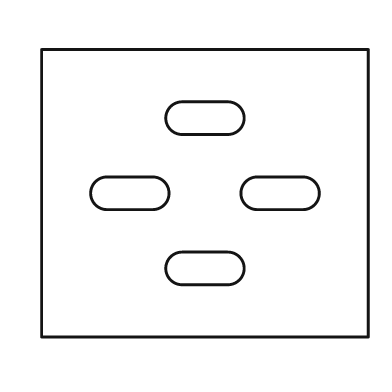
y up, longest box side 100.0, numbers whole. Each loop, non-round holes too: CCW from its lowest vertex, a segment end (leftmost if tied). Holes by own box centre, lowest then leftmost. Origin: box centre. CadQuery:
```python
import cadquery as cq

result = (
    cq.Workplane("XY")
    .moveTo(-50.0, -44.0)
    .lineTo(50.0, -44.0)
    .lineTo(50.0, 44.0)
    .lineTo(-50.0, 44.0)
    .close()
    .moveTo(-7.0, -28.0)
    .lineTo(7.0, -28.0)
    .threePointArc((12.0, -23.0), (7.0, -18.0))
    .lineTo(-7.0, -18.0)
    .threePointArc((-12.0, -23.0), (-7.0, -28.0))
    .close()
    .moveTo(-30.0, -5.0)
    .lineTo(-16.0, -5.0)
    .threePointArc((-11.0, 0.0), (-16.0, 5.0))
    .lineTo(-30.0, 5.0)
    .threePointArc((-35.0, 0.0), (-30.0, -5.0))
    .close()
    .moveTo(16.0, -5.0)
    .lineTo(30.0, -5.0)
    .threePointArc((35.0, 0.0), (30.0, 5.0))
    .lineTo(16.0, 5.0)
    .threePointArc((11.0, 0.0), (16.0, -5.0))
    .close()
    .moveTo(-7.0, 18.0)
    .lineTo(7.0, 18.0)
    .threePointArc((12.0, 23.0), (7.0, 28.0))
    .lineTo(-7.0, 28.0)
    .threePointArc((-12.0, 23.0), (-7.0, 18.0))
    .close()
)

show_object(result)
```